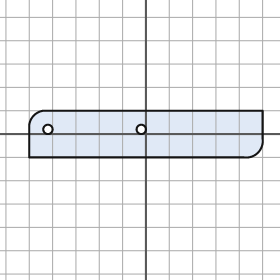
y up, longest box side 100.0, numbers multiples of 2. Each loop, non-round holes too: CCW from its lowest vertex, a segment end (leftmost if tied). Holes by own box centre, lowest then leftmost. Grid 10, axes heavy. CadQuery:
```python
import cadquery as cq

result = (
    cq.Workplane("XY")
    .moveTo(-50.0, -10.0)
    .lineTo(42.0, -10.0)
    .threePointArc((48.0, -8.0), (50.0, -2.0))
    .lineTo(50.0, 10.0)
    .lineTo(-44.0, 10.0)
    .threePointArc((-48.0, 8.0), (-50.0, 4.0))
    .close()
    .moveTo(-42.0, 2.0)
    .circle(2.0)
    .moveTo(-2.0, 2.0)
    .circle(2.0)
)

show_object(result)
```